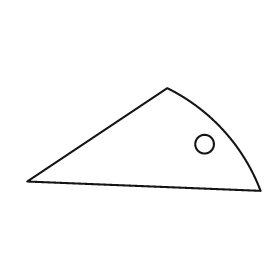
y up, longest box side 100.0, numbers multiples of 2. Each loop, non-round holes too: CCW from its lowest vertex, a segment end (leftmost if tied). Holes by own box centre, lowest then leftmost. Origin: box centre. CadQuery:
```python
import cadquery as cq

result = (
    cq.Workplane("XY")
    .moveTo(50.0, -22.0)
    .threePointArc((34.0, 4.0), (10.0, 22.0))
    .lineTo(-50.0, -18.0)
    .close()
    .moveTo(26.0, -2.0)
    .circle(4.0)
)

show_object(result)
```